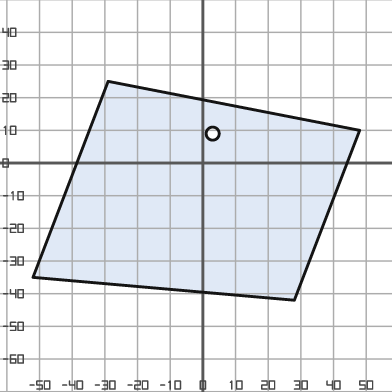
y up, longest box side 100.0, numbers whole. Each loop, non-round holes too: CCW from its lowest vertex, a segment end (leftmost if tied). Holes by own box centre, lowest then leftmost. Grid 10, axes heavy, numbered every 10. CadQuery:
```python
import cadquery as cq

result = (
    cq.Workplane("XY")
    .moveTo(28.0, -42.0)
    .lineTo(48.0, 10.0)
    .lineTo(-29.0, 25.0)
    .lineTo(-52.0, -35.0)
    .close()
    .moveTo(3.0, 9.0)
    .circle(2.0)
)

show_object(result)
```